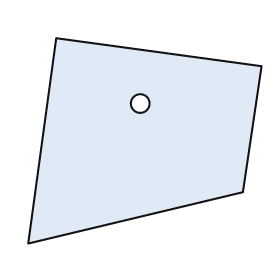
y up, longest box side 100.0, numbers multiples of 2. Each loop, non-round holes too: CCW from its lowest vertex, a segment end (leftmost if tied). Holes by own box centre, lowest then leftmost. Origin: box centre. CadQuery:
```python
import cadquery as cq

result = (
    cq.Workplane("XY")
    .moveTo(-50.0, -44.0)
    .lineTo(42.0, -22.0)
    .lineTo(50.0, 32.0)
    .lineTo(-38.0, 44.0)
    .close()
    .moveTo(-2.0, 16.0)
    .circle(4.0)
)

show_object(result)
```